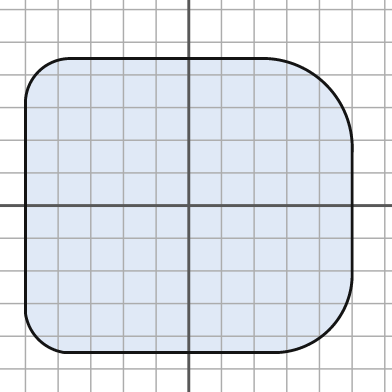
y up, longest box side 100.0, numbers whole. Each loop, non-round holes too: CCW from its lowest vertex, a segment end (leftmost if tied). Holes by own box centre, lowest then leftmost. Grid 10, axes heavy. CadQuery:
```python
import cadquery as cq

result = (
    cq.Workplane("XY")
    .moveTo(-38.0, -45.0)
    .lineTo(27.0, -45.0)
    .threePointArc((43.0, -38.0), (50.0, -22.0))
    .lineTo(50.0, 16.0)
    .threePointArc((42.0, 37.0), (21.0, 45.0))
    .lineTo(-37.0, 45.0)
    .threePointArc((-46.0, 41.0), (-50.0, 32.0))
    .lineTo(-50.0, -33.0)
    .threePointArc((-46.0, -41.0), (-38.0, -45.0))
    .close()
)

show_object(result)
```